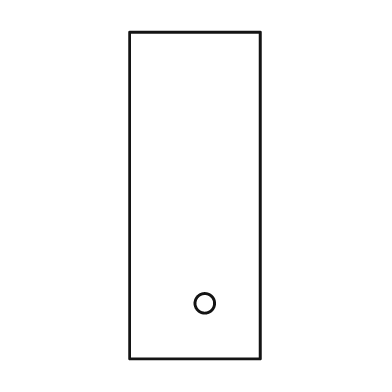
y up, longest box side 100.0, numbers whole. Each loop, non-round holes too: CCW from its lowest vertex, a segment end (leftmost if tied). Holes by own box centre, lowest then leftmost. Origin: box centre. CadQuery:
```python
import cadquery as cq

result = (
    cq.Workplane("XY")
    .moveTo(-20.0, -50.0)
    .lineTo(20.0, -50.0)
    .lineTo(20.0, 50.0)
    .lineTo(-20.0, 50.0)
    .close()
    .moveTo(3.0, -33.0)
    .circle(3.0)
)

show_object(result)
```